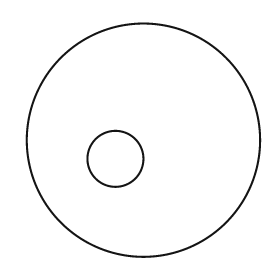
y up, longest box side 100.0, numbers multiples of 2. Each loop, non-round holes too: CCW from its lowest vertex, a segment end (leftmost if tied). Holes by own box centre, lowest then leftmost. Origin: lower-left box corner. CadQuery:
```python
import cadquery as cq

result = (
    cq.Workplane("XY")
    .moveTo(50.0, 50.0)
    .circle(50.0)
    .moveTo(38.0, 42.0)
    .circle(12.0)
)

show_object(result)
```